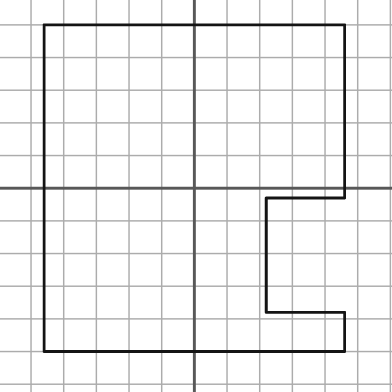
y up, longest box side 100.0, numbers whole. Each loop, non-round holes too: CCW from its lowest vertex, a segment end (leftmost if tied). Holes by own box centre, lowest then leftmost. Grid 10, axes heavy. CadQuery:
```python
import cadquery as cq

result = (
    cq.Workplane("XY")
    .moveTo(-46.0, -50.0)
    .lineTo(46.0, -50.0)
    .lineTo(46.0, -38.0)
    .lineTo(22.0, -38.0)
    .lineTo(22.0, -3.0)
    .lineTo(46.0, -3.0)
    .lineTo(46.0, 50.0)
    .lineTo(-46.0, 50.0)
    .close()
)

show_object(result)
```